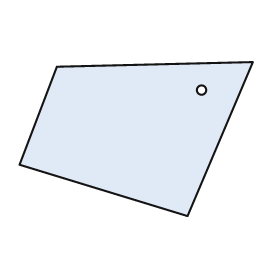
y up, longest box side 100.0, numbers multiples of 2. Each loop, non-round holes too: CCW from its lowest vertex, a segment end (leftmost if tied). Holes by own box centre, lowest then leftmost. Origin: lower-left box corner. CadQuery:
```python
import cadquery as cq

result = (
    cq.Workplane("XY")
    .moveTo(72.0, 0.0)
    .lineTo(100.0, 66.0)
    .lineTo(16.0, 64.0)
    .lineTo(0.0, 22.0)
    .close()
    .moveTo(78.0, 54.0)
    .circle(2.0)
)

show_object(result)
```